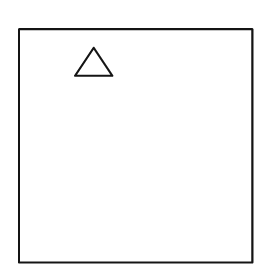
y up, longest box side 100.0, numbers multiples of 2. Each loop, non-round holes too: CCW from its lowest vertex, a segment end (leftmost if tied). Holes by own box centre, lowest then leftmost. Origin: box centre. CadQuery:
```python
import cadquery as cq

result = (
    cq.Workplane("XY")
    .moveTo(-50.0, -50.0)
    .lineTo(50.0, -50.0)
    .lineTo(50.0, 50.0)
    .lineTo(-50.0, 50.0)
    .close()
    .moveTo(-26.0, 30.0)
    .lineTo(-10.0, 30.0)
    .lineTo(-18.0, 42.0)
    .close()
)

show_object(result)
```